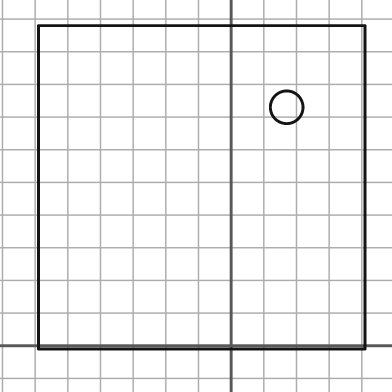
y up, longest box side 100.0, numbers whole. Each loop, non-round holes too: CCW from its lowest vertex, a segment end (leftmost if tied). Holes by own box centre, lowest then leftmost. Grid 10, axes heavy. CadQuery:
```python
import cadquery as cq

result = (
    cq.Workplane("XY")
    .moveTo(-59.0, -1.0)
    .lineTo(41.0, -1.0)
    .lineTo(41.0, 98.0)
    .lineTo(-59.0, 98.0)
    .close()
    .moveTo(17.0, 73.0)
    .circle(5.0)
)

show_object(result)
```